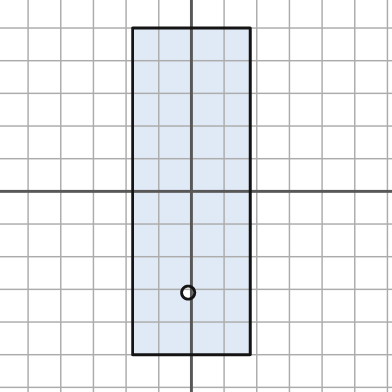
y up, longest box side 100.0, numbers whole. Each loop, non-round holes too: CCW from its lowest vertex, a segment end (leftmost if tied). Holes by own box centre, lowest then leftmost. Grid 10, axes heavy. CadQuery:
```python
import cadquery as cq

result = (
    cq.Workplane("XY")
    .moveTo(-18.0, -50.0)
    .lineTo(18.0, -50.0)
    .lineTo(18.0, 50.0)
    .lineTo(-18.0, 50.0)
    .close()
    .moveTo(-1.0, -31.0)
    .circle(2.0)
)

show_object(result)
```